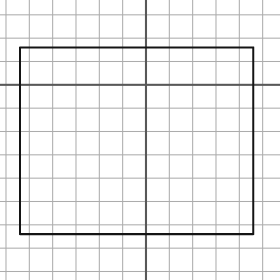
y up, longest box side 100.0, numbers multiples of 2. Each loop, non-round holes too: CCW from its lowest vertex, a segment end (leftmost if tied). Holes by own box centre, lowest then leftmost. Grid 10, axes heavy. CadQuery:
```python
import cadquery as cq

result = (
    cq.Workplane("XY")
    .moveTo(-54.0, -64.0)
    .lineTo(46.0, -64.0)
    .lineTo(46.0, 16.0)
    .lineTo(-54.0, 16.0)
    .close()
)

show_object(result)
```